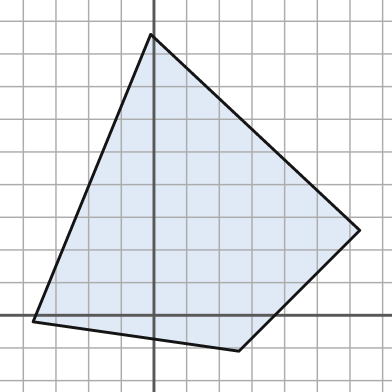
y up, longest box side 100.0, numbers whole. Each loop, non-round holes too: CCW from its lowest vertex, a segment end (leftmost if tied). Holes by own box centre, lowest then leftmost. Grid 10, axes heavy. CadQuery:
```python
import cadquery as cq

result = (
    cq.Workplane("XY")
    .moveTo(26.0, -11.0)
    .lineTo(63.0, 26.0)
    .lineTo(-1.0, 86.0)
    .lineTo(-37.0, -2.0)
    .close()
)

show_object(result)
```